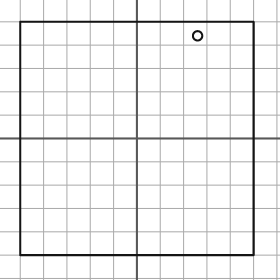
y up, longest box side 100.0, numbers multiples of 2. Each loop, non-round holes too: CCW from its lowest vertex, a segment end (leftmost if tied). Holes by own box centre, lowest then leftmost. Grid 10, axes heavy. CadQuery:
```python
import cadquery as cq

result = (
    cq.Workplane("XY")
    .moveTo(-50.0, -50.0)
    .lineTo(50.0, -50.0)
    .lineTo(50.0, 50.0)
    .lineTo(-50.0, 50.0)
    .close()
    .moveTo(26.0, 44.0)
    .circle(2.0)
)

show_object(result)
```